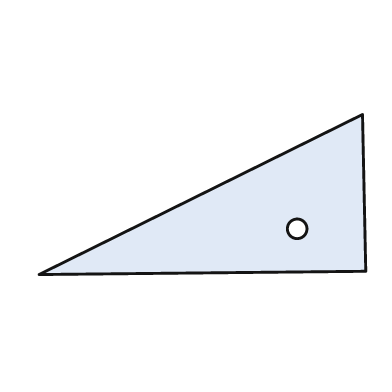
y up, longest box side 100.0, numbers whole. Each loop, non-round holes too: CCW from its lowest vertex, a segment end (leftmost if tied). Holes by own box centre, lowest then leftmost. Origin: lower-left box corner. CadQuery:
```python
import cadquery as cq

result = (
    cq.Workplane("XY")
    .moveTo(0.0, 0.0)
    .lineTo(100.0, 1.0)
    .lineTo(99.0, 49.0)
    .close()
    .moveTo(79.0, 14.0)
    .circle(3.0)
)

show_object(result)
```